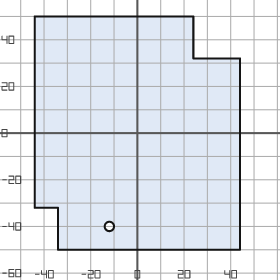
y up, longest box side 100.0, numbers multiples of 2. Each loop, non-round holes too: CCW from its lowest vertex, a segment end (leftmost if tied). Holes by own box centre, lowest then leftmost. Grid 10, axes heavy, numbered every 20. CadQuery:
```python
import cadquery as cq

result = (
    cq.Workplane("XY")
    .moveTo(-34.0, -50.0)
    .lineTo(44.0, -50.0)
    .lineTo(44.0, 32.0)
    .lineTo(24.0, 32.0)
    .lineTo(24.0, 50.0)
    .lineTo(-44.0, 50.0)
    .lineTo(-44.0, -32.0)
    .lineTo(-34.0, -32.0)
    .close()
    .moveTo(-12.0, -40.0)
    .circle(2.0)
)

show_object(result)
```